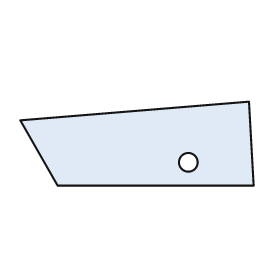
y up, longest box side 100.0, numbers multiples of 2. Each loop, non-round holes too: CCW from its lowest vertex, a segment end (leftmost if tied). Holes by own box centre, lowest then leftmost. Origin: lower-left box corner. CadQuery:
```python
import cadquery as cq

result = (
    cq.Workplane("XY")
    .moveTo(16.0, 0.0)
    .lineTo(100.0, 0.0)
    .lineTo(98.0, 36.0)
    .lineTo(0.0, 28.0)
    .close()
    .moveTo(72.0, 10.0)
    .circle(4.0)
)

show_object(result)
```